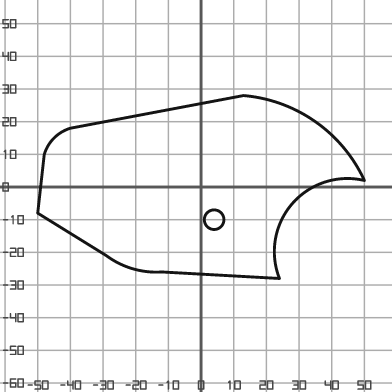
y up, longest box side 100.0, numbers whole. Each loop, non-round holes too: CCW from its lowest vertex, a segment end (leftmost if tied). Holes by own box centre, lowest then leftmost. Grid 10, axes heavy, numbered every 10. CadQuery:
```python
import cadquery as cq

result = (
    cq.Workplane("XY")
    .moveTo(24.0, -28.0)
    .threePointArc((28.0, -5.0), (50.0, 2.0))
    .threePointArc((35.0, 20.0), (13.0, 28.0))
    .lineTo(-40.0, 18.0)
    .threePointArc((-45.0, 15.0), (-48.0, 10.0))
    .lineTo(-50.0, -8.0)
    .lineTo(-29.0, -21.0)
    .threePointArc((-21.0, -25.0), (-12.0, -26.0))
    .close()
    .moveTo(4.0, -10.0)
    .circle(3.0)
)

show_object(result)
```